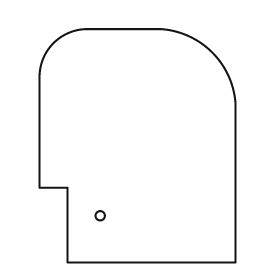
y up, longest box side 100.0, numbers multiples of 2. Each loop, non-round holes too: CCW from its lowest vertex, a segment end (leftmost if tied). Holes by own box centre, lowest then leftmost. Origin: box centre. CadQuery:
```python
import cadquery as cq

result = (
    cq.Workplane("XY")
    .moveTo(-30.0, -50.0)
    .lineTo(42.0, -50.0)
    .lineTo(42.0, 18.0)
    .threePointArc((32.0, 40.0), (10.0, 50.0))
    .lineTo(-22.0, 50.0)
    .threePointArc((-36.0, 44.0), (-42.0, 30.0))
    .lineTo(-42.0, -18.0)
    .lineTo(-30.0, -18.0)
    .close()
    .moveTo(-16.0, -30.0)
    .circle(2.0)
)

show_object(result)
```